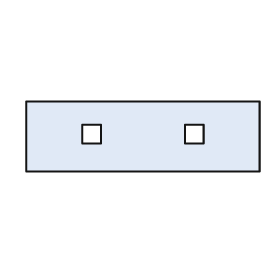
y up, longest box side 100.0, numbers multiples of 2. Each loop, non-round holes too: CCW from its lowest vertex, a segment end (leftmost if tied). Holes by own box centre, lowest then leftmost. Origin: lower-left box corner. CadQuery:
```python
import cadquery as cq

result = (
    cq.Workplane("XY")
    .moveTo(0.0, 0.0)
    .lineTo(100.0, 0.0)
    .lineTo(100.0, 30.0)
    .lineTo(0.0, 30.0)
    .close()
    .moveTo(24.0, 12.0)
    .lineTo(32.0, 12.0)
    .lineTo(32.0, 20.0)
    .lineTo(24.0, 20.0)
    .close()
    .moveTo(68.0, 12.0)
    .lineTo(76.0, 12.0)
    .lineTo(76.0, 20.0)
    .lineTo(68.0, 20.0)
    .close()
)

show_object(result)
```